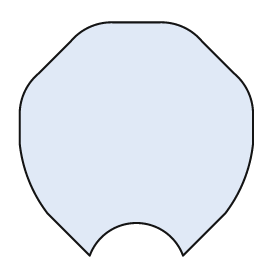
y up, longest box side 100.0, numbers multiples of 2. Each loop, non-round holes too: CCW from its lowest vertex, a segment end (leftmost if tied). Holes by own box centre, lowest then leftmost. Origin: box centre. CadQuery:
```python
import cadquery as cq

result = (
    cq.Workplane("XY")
    .moveTo(-20.0, -50.0)
    .threePointArc((0.0, -36.0), (20.0, -50.0))
    .lineTo(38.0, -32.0)
    .threePointArc((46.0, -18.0), (50.0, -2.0))
    .lineTo(50.0, 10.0)
    .threePointArc((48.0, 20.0), (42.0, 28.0))
    .lineTo(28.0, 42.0)
    .threePointArc((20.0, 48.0), (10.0, 50.0))
    .lineTo(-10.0, 50.0)
    .threePointArc((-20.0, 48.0), (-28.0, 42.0))
    .lineTo(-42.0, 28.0)
    .threePointArc((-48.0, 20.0), (-50.0, 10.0))
    .lineTo(-50.0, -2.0)
    .threePointArc((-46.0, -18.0), (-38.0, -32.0))
    .close()
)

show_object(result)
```